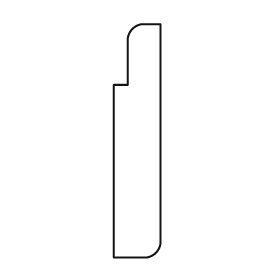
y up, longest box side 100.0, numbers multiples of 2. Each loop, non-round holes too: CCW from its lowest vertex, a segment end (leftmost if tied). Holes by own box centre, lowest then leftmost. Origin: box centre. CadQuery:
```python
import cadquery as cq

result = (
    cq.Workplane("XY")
    .moveTo(-10.0, -50.0)
    .lineTo(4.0, -50.0)
    .threePointArc((8.0, -48.0), (10.0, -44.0))
    .lineTo(10.0, 50.0)
    .lineTo(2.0, 50.0)
    .threePointArc((-2.0, 48.0), (-4.0, 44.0))
    .lineTo(-4.0, 24.0)
    .lineTo(-10.0, 24.0)
    .close()
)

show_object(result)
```